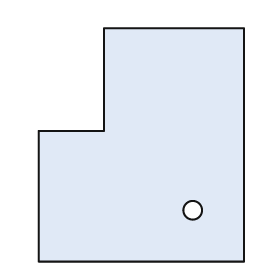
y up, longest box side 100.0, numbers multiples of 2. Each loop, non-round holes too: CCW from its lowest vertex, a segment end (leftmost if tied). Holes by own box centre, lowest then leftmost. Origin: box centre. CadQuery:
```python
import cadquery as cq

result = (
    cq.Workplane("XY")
    .moveTo(-44.0, -50.0)
    .lineTo(44.0, -50.0)
    .lineTo(44.0, 50.0)
    .lineTo(-16.0, 50.0)
    .lineTo(-16.0, 6.0)
    .lineTo(-44.0, 6.0)
    .close()
    .moveTo(22.0, -28.0)
    .circle(4.0)
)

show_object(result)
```